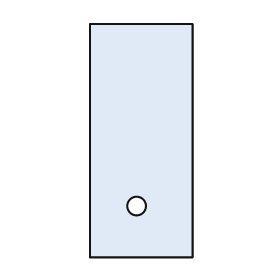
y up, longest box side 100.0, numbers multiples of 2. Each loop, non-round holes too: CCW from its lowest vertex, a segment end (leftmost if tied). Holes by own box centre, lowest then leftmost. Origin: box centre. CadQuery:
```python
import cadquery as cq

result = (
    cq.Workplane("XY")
    .moveTo(-22.0, -50.0)
    .lineTo(22.0, -50.0)
    .lineTo(22.0, 50.0)
    .lineTo(-22.0, 50.0)
    .close()
    .moveTo(-2.0, -28.0)
    .circle(4.0)
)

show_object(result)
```